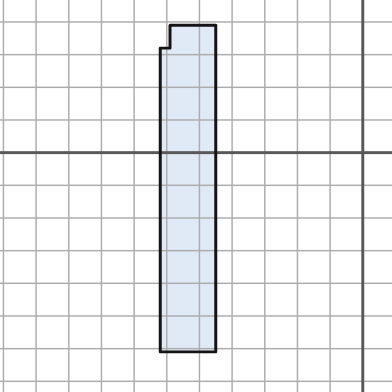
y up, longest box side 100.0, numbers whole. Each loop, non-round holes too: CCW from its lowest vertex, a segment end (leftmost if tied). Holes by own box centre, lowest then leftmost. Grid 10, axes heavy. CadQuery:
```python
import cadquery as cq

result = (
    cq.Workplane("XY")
    .moveTo(-62.0, -61.0)
    .lineTo(-45.0, -61.0)
    .lineTo(-45.0, 39.0)
    .lineTo(-59.0, 39.0)
    .lineTo(-59.0, 32.0)
    .lineTo(-62.0, 32.0)
    .close()
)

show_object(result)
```